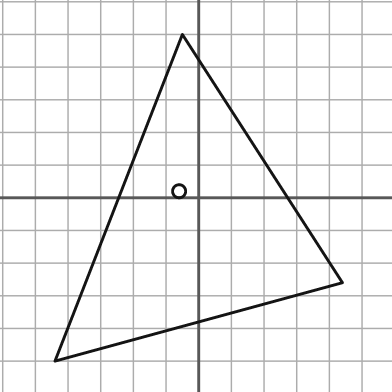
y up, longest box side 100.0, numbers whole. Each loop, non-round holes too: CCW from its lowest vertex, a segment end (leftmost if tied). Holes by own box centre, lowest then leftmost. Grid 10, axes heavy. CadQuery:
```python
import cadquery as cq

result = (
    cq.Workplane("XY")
    .moveTo(-44.0, -50.0)
    .lineTo(44.0, -26.0)
    .lineTo(-5.0, 50.0)
    .close()
    .moveTo(-6.0, 2.0)
    .circle(2.0)
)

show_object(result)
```